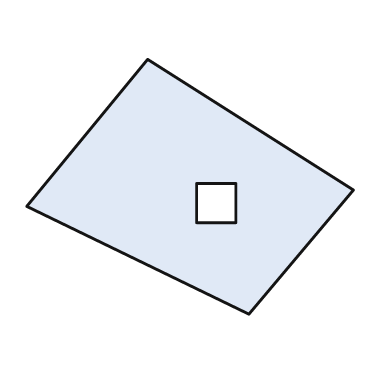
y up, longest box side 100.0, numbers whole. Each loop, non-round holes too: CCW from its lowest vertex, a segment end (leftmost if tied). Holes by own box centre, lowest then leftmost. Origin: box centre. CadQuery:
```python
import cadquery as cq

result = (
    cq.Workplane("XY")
    .moveTo(18.0, -39.0)
    .lineTo(50.0, -1.0)
    .lineTo(-13.0, 39.0)
    .lineTo(-50.0, -6.0)
    .close()
    .moveTo(2.0, -11.0)
    .lineTo(14.0, -11.0)
    .lineTo(14.0, 1.0)
    .lineTo(2.0, 1.0)
    .close()
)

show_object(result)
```